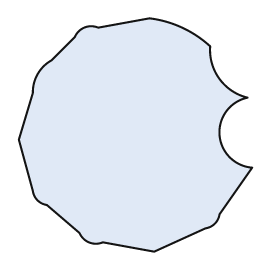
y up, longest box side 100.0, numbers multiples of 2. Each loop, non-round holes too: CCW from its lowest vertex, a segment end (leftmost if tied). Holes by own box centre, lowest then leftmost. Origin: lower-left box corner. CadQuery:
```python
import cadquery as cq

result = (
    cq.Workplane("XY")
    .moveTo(58.0, 0.0)
    .lineTo(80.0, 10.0)
    .threePointArc((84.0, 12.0), (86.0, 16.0))
    .lineTo(100.0, 36.0)
    .threePointArc((86.0, 50.0), (98.0, 66.0))
    .threePointArc((86.0, 74.0), (82.0, 88.0))
    .threePointArc((70.0, 96.0), (56.0, 100.0))
    .lineTo(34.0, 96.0)
    .threePointArc((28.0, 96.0), (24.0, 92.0))
    .lineTo(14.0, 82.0)
    .threePointArc((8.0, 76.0), (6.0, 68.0))
    .lineTo(0.0, 48.0)
    .lineTo(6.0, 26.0)
    .threePointArc((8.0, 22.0), (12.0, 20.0))
    .lineTo(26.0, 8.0)
    .threePointArc((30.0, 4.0), (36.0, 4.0))
    .close()
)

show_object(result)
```